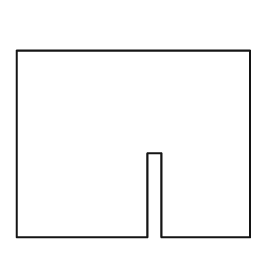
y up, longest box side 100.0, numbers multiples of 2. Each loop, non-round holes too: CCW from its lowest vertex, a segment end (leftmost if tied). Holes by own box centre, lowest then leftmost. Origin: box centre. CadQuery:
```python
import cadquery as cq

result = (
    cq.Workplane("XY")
    .moveTo(-50.0, -40.0)
    .lineTo(6.0, -40.0)
    .lineTo(6.0, -4.0)
    .lineTo(12.0, -4.0)
    .lineTo(12.0, -40.0)
    .lineTo(50.0, -40.0)
    .lineTo(50.0, 40.0)
    .lineTo(-50.0, 40.0)
    .close()
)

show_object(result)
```